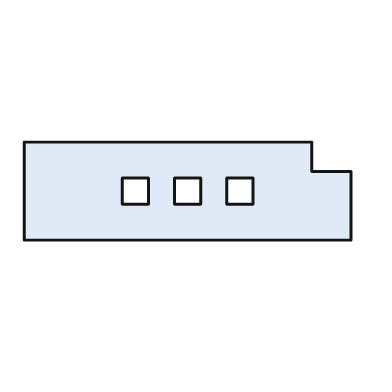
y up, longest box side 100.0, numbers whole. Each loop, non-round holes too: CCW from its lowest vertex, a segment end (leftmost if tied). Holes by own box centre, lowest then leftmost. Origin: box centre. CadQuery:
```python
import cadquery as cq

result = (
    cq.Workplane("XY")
    .moveTo(-50.0, -15.0)
    .lineTo(50.0, -15.0)
    .lineTo(50.0, 6.0)
    .lineTo(38.0, 6.0)
    .lineTo(38.0, 15.0)
    .lineTo(-50.0, 15.0)
    .close()
    .moveTo(-20.0, -4.0)
    .lineTo(-12.0, -4.0)
    .lineTo(-12.0, 4.0)
    .lineTo(-20.0, 4.0)
    .close()
    .moveTo(-4.0, -4.0)
    .lineTo(4.0, -4.0)
    .lineTo(4.0, 4.0)
    .lineTo(-4.0, 4.0)
    .close()
    .moveTo(12.0, -4.0)
    .lineTo(20.0, -4.0)
    .lineTo(20.0, 4.0)
    .lineTo(12.0, 4.0)
    .close()
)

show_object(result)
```